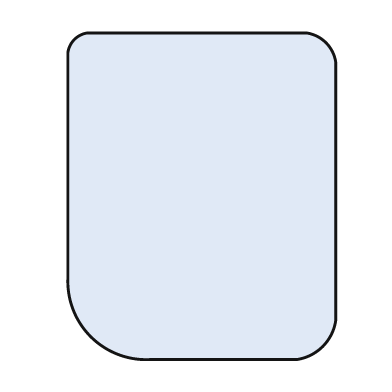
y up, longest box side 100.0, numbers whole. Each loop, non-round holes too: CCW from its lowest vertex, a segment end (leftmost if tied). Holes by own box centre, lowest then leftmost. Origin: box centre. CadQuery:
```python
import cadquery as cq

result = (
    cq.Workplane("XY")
    .moveTo(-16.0, -50.0)
    .lineTo(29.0, -50.0)
    .threePointArc((37.0, -46.0), (41.0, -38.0))
    .lineTo(41.0, 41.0)
    .threePointArc((38.0, 47.0), (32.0, 50.0))
    .lineTo(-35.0, 50.0)
    .threePointArc((-39.0, 48.0), (-41.0, 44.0))
    .lineTo(-41.0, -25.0)
    .threePointArc((-34.0, -43.0), (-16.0, -50.0))
    .close()
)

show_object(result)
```